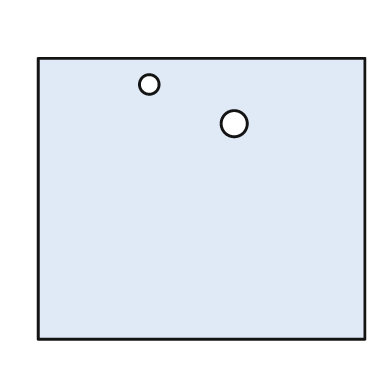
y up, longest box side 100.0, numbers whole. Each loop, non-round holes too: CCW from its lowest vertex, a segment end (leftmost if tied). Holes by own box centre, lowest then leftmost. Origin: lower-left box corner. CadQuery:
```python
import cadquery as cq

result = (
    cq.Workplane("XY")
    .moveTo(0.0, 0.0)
    .lineTo(100.0, 0.0)
    .lineTo(100.0, 86.0)
    .lineTo(0.0, 86.0)
    .close()
    .moveTo(60.0, 66.0)
    .circle(4.0)
    .moveTo(34.0, 78.0)
    .circle(3.0)
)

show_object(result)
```